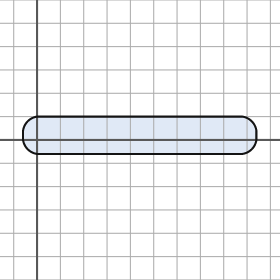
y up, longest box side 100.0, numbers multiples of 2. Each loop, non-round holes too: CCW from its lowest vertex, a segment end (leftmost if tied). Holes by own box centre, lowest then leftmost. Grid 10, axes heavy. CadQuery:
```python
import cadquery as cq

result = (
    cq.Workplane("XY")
    .moveTo(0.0, -6.0)
    .lineTo(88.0, -6.0)
    .threePointArc((92.0, -4.0), (94.0, 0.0))
    .lineTo(94.0, 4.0)
    .threePointArc((92.0, 8.0), (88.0, 10.0))
    .lineTo(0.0, 10.0)
    .threePointArc((-4.0, 8.0), (-6.0, 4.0))
    .lineTo(-6.0, 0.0)
    .threePointArc((-4.0, -4.0), (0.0, -6.0))
    .close()
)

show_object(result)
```